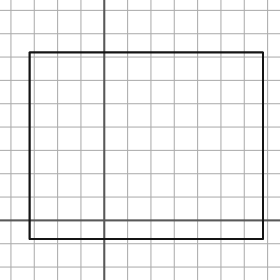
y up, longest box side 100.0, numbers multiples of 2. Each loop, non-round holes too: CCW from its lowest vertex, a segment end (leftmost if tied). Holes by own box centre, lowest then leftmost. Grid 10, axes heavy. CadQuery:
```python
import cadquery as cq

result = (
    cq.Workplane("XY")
    .moveTo(-32.0, -8.0)
    .lineTo(68.0, -8.0)
    .lineTo(68.0, 72.0)
    .lineTo(-32.0, 72.0)
    .close()
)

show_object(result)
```